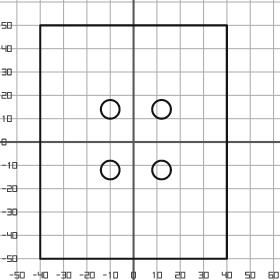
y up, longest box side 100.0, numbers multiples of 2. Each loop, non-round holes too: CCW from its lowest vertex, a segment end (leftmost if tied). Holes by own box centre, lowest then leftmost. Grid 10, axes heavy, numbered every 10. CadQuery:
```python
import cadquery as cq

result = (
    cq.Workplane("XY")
    .moveTo(-40.0, -50.0)
    .lineTo(40.0, -50.0)
    .lineTo(40.0, 50.0)
    .lineTo(-40.0, 50.0)
    .close()
    .moveTo(-10.0, -12.0)
    .circle(4.0)
    .moveTo(12.0, -12.0)
    .circle(4.0)
    .moveTo(-10.0, 14.0)
    .circle(4.0)
    .moveTo(12.0, 14.0)
    .circle(4.0)
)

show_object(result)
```